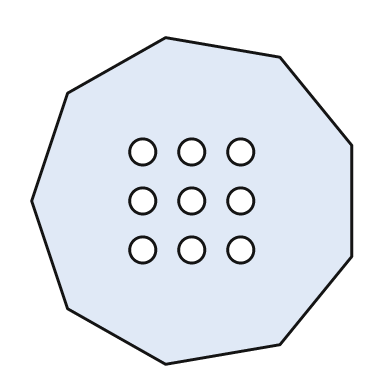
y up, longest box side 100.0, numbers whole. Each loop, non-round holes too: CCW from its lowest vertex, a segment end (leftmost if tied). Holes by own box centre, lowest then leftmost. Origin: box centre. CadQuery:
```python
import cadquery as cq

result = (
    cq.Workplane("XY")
    .moveTo(-8.0, -50.0)
    .lineTo(27.0, -44.0)
    .lineTo(49.0, -17.0)
    .lineTo(49.0, 17.0)
    .lineTo(27.0, 44.0)
    .lineTo(-8.0, 50.0)
    .lineTo(-38.0, 33.0)
    .lineTo(-49.0, 0.0)
    .lineTo(-38.0, -33.0)
    .close()
    .moveTo(-15.0, -15.0)
    .circle(4.0)
    .moveTo(0.0, -15.0)
    .circle(4.0)
    .moveTo(15.0, -15.0)
    .circle(4.0)
    .moveTo(-15.0, 0.0)
    .circle(4.0)
    .moveTo(0.0, 0.0)
    .circle(4.0)
    .moveTo(15.0, 0.0)
    .circle(4.0)
    .moveTo(-15.0, 15.0)
    .circle(4.0)
    .moveTo(0.0, 15.0)
    .circle(4.0)
    .moveTo(15.0, 15.0)
    .circle(4.0)
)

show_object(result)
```